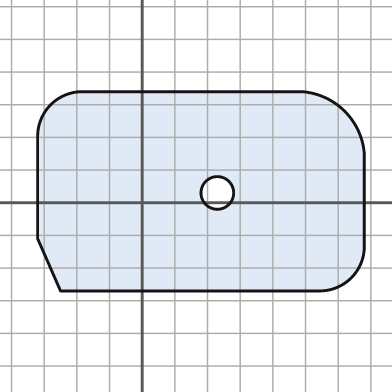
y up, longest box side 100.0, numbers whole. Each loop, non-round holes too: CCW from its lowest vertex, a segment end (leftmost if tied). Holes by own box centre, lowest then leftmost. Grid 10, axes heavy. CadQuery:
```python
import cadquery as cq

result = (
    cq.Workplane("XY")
    .moveTo(-25.0, -27.0)
    .lineTo(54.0, -27.0)
    .threePointArc((64.0, -23.0), (68.0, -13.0))
    .lineTo(68.0, 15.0)
    .threePointArc((62.0, 28.0), (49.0, 34.0))
    .lineTo(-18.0, 34.0)
    .threePointArc((-28.0, 30.0), (-32.0, 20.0))
    .lineTo(-32.0, -11.0)
    .close()
    .moveTo(23.0, 3.0)
    .circle(5.0)
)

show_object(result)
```